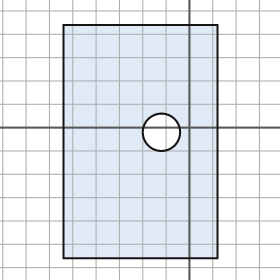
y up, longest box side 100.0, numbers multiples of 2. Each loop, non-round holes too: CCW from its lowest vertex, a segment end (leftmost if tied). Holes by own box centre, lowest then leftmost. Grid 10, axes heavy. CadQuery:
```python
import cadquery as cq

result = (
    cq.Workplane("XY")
    .moveTo(-54.0, -56.0)
    .lineTo(12.0, -56.0)
    .lineTo(12.0, 44.0)
    .lineTo(-54.0, 44.0)
    .close()
    .moveTo(-12.0, -2.0)
    .circle(8.0)
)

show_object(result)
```